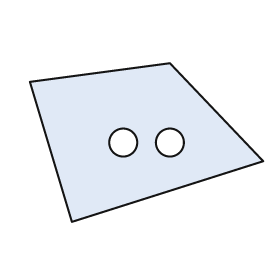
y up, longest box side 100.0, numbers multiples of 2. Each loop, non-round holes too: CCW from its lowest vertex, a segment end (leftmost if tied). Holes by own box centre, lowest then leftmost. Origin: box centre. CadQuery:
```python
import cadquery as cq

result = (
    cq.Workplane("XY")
    .moveTo(-32.0, -34.0)
    .lineTo(50.0, -8.0)
    .lineTo(10.0, 34.0)
    .lineTo(-50.0, 26.0)
    .close()
    .moveTo(-10.0, 0.0)
    .circle(6.0)
    .moveTo(10.0, 0.0)
    .circle(6.0)
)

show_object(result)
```